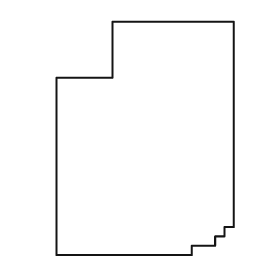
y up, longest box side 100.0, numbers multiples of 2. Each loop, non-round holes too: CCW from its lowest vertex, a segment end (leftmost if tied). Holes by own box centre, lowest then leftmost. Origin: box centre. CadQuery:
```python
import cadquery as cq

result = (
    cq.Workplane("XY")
    .moveTo(-38.0, -50.0)
    .lineTo(20.0, -50.0)
    .lineTo(20.0, -46.0)
    .lineTo(30.0, -46.0)
    .lineTo(30.0, -42.0)
    .lineTo(34.0, -42.0)
    .lineTo(34.0, -38.0)
    .lineTo(38.0, -38.0)
    .lineTo(38.0, 50.0)
    .lineTo(-14.0, 50.0)
    .lineTo(-14.0, 26.0)
    .lineTo(-38.0, 26.0)
    .close()
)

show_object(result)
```